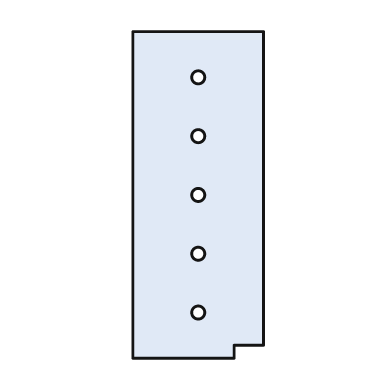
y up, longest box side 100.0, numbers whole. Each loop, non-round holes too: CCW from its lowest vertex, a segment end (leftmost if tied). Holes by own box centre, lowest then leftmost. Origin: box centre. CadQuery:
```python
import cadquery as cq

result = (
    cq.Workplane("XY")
    .moveTo(-20.0, -50.0)
    .lineTo(11.0, -50.0)
    .lineTo(11.0, -46.0)
    .lineTo(20.0, -46.0)
    .lineTo(20.0, 50.0)
    .lineTo(-20.0, 50.0)
    .close()
    .moveTo(0.0, -36.0)
    .circle(2.0)
    .moveTo(0.0, -18.0)
    .circle(2.0)
    .moveTo(0.0, 0.0)
    .circle(2.0)
    .moveTo(0.0, 18.0)
    .circle(2.0)
    .moveTo(0.0, 36.0)
    .circle(2.0)
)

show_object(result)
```